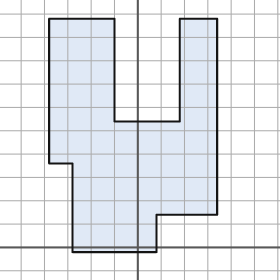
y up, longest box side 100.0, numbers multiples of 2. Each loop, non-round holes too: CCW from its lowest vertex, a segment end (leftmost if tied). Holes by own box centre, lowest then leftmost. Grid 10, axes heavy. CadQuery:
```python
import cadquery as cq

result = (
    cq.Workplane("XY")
    .moveTo(-28.0, -2.0)
    .lineTo(8.0, -2.0)
    .lineTo(8.0, 14.0)
    .lineTo(34.0, 14.0)
    .lineTo(34.0, 98.0)
    .lineTo(18.0, 98.0)
    .lineTo(18.0, 54.0)
    .lineTo(-10.0, 54.0)
    .lineTo(-10.0, 98.0)
    .lineTo(-38.0, 98.0)
    .lineTo(-38.0, 36.0)
    .lineTo(-28.0, 36.0)
    .close()
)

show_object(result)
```